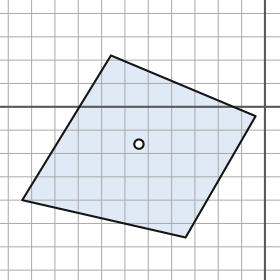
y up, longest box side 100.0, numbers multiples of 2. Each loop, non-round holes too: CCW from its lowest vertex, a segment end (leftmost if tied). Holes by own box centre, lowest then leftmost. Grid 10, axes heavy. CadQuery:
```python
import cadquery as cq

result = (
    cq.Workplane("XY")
    .moveTo(-34.0, -56.0)
    .lineTo(-4.0, -4.0)
    .lineTo(-66.0, 22.0)
    .lineTo(-104.0, -40.0)
    .close()
    .moveTo(-54.0, -16.0)
    .circle(2.0)
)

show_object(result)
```